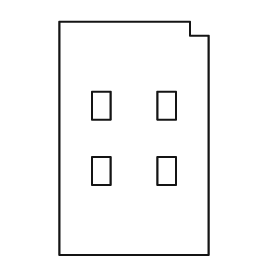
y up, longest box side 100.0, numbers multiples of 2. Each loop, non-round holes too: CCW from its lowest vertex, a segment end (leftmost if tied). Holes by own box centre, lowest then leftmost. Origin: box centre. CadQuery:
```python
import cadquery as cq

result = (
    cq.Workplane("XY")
    .moveTo(-32.0, -50.0)
    .lineTo(32.0, -50.0)
    .lineTo(32.0, 44.0)
    .lineTo(24.0, 44.0)
    .lineTo(24.0, 50.0)
    .lineTo(-32.0, 50.0)
    .close()
    .moveTo(-18.0, -20.0)
    .lineTo(-10.0, -20.0)
    .lineTo(-10.0, -8.0)
    .lineTo(-18.0, -8.0)
    .close()
    .moveTo(10.0, -20.0)
    .lineTo(18.0, -20.0)
    .lineTo(18.0, -8.0)
    .lineTo(10.0, -8.0)
    .close()
    .moveTo(-18.0, 8.0)
    .lineTo(-10.0, 8.0)
    .lineTo(-10.0, 20.0)
    .lineTo(-18.0, 20.0)
    .close()
    .moveTo(10.0, 8.0)
    .lineTo(18.0, 8.0)
    .lineTo(18.0, 20.0)
    .lineTo(10.0, 20.0)
    .close()
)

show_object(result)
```